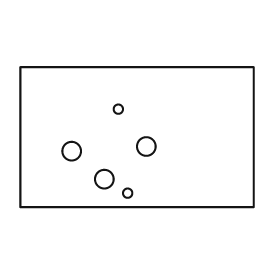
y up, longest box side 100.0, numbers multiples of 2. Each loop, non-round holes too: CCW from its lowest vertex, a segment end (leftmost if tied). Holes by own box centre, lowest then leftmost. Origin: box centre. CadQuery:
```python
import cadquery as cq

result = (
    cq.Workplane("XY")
    .moveTo(-50.0, -30.0)
    .lineTo(50.0, -30.0)
    .lineTo(50.0, 30.0)
    .lineTo(-50.0, 30.0)
    .close()
    .moveTo(-4.0, -24.0)
    .circle(2.0)
    .moveTo(-14.0, -18.0)
    .circle(4.0)
    .moveTo(-28.0, -6.0)
    .circle(4.0)
    .moveTo(4.0, -4.0)
    .circle(4.0)
    .moveTo(-8.0, 12.0)
    .circle(2.0)
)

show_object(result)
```